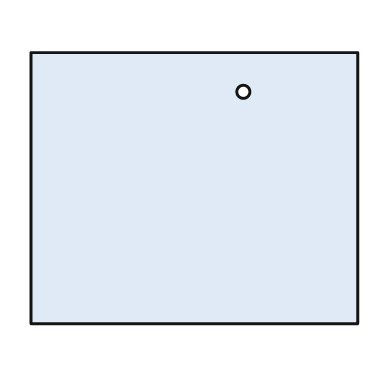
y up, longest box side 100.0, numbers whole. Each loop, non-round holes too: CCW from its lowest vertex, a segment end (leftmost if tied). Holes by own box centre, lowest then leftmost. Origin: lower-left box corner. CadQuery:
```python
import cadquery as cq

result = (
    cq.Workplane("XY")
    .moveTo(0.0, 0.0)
    .lineTo(100.0, 0.0)
    .lineTo(100.0, 83.0)
    .lineTo(0.0, 83.0)
    .close()
    .moveTo(65.0, 71.0)
    .circle(2.0)
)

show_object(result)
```